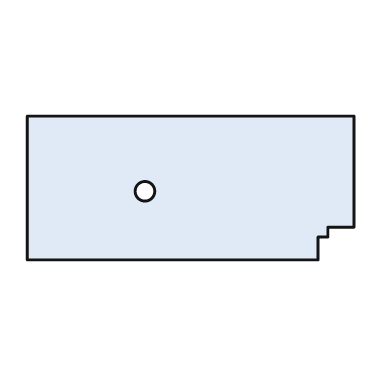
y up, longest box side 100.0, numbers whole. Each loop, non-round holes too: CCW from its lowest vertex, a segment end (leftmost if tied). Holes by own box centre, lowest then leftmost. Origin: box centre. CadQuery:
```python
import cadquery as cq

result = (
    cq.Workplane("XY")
    .moveTo(-50.0, -22.0)
    .lineTo(39.0, -22.0)
    .lineTo(39.0, -15.0)
    .lineTo(42.0, -15.0)
    .lineTo(42.0, -12.0)
    .lineTo(50.0, -12.0)
    .lineTo(50.0, 22.0)
    .lineTo(-50.0, 22.0)
    .close()
    .moveTo(-14.0, -1.0)
    .circle(3.0)
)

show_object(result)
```